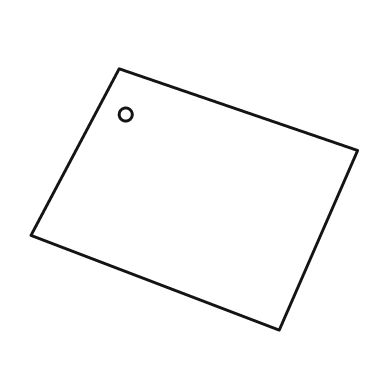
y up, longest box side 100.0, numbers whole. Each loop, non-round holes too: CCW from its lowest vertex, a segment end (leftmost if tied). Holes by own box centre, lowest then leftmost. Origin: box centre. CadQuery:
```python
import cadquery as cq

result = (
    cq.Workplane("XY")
    .moveTo(26.0, -40.0)
    .lineTo(50.0, 15.0)
    .lineTo(-23.0, 40.0)
    .lineTo(-50.0, -11.0)
    .close()
    .moveTo(-21.0, 26.0)
    .circle(2.0)
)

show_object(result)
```